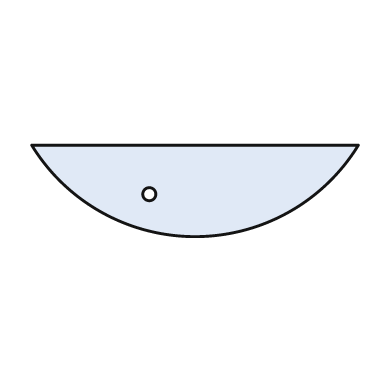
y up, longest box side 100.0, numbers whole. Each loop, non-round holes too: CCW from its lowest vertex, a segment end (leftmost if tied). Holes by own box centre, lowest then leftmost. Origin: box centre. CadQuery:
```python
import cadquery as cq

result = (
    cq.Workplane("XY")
    .moveTo(-50.0, 14.0)
    .threePointArc((0.0, -14.0), (50.0, 14.0))
    .close()
    .moveTo(-14.0, -1.0)
    .circle(2.0)
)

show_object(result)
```